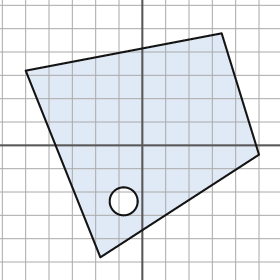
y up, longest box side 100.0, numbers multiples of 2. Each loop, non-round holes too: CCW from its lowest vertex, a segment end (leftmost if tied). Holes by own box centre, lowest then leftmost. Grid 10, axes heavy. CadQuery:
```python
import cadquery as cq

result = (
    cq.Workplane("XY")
    .moveTo(-18.0, -48.0)
    .lineTo(50.0, -4.0)
    .lineTo(34.0, 48.0)
    .lineTo(-50.0, 32.0)
    .close()
    .moveTo(-8.0, -24.0)
    .circle(6.0)
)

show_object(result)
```